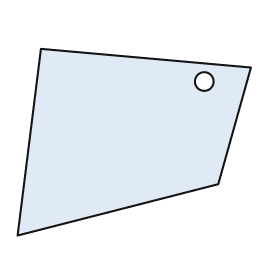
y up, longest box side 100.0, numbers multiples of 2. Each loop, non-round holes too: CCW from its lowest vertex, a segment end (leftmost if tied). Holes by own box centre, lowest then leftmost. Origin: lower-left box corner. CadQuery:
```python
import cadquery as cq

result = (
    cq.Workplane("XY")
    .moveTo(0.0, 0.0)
    .lineTo(86.0, 22.0)
    .lineTo(100.0, 72.0)
    .lineTo(10.0, 80.0)
    .close()
    .moveTo(80.0, 66.0)
    .circle(4.0)
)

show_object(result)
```